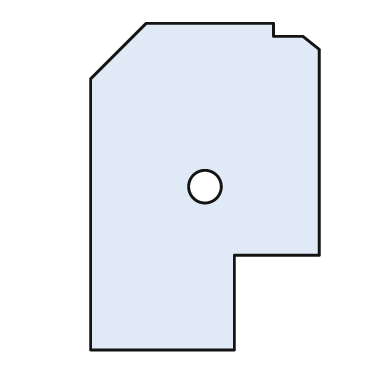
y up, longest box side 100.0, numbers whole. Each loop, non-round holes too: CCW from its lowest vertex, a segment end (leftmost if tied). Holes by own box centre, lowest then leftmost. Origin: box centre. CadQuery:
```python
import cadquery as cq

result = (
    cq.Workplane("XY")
    .moveTo(-35.0, -50.0)
    .lineTo(9.0, -50.0)
    .lineTo(9.0, -21.0)
    .lineTo(35.0, -21.0)
    .lineTo(35.0, 42.0)
    .lineTo(30.0, 46.0)
    .lineTo(21.0, 46.0)
    .lineTo(21.0, 50.0)
    .lineTo(-18.0, 50.0)
    .lineTo(-35.0, 33.0)
    .close()
    .moveTo(0.0, 0.0)
    .circle(5.0)
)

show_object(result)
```